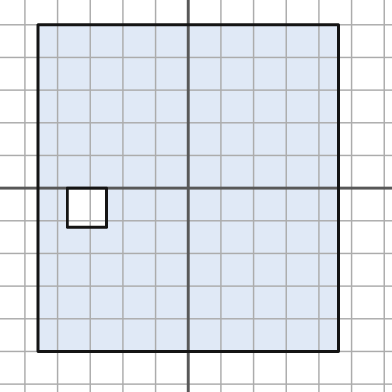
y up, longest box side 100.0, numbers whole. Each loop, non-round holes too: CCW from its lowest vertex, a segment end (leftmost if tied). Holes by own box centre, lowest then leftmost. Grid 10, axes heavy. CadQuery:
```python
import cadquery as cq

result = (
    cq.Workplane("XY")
    .moveTo(-46.0, -50.0)
    .lineTo(46.0, -50.0)
    .lineTo(46.0, 50.0)
    .lineTo(-46.0, 50.0)
    .close()
    .moveTo(-37.0, -12.0)
    .lineTo(-25.0, -12.0)
    .lineTo(-25.0, 0.0)
    .lineTo(-37.0, 0.0)
    .close()
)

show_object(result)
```